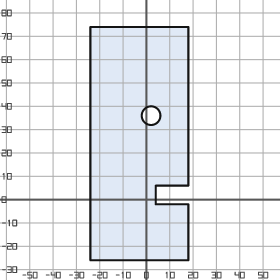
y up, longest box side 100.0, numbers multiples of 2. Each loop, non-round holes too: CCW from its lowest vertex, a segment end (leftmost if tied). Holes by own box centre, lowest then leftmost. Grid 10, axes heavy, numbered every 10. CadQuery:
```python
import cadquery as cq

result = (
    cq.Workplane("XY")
    .moveTo(-24.0, -26.0)
    .lineTo(18.0, -26.0)
    .lineTo(18.0, -2.0)
    .lineTo(4.0, -2.0)
    .lineTo(4.0, 6.0)
    .lineTo(18.0, 6.0)
    .lineTo(18.0, 74.0)
    .lineTo(-24.0, 74.0)
    .close()
    .moveTo(2.0, 36.0)
    .circle(4.0)
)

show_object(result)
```